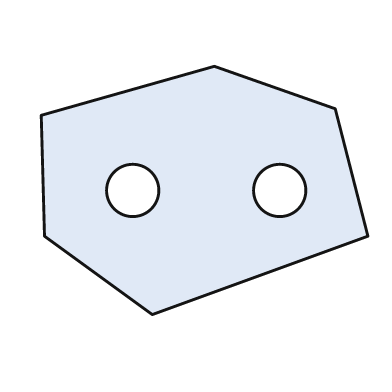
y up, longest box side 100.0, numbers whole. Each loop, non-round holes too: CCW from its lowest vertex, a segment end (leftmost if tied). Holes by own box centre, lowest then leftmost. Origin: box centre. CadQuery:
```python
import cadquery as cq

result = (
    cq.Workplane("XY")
    .moveTo(-16.0, -38.0)
    .lineTo(50.0, -14.0)
    .lineTo(40.0, 25.0)
    .lineTo(3.0, 38.0)
    .lineTo(-50.0, 23.0)
    .lineTo(-49.0, -14.0)
    .close()
    .moveTo(-22.0, 0.0)
    .circle(8.0)
    .moveTo(23.0, 0.0)
    .circle(8.0)
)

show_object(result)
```